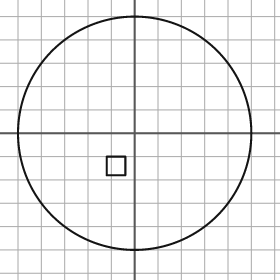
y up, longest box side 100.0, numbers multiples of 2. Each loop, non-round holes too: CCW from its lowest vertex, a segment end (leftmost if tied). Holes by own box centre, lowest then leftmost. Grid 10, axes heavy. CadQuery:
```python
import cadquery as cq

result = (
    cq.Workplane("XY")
    .moveTo(0.0, 0.0)
    .circle(50.0)
    .moveTo(-12.0, -18.0)
    .lineTo(-4.0, -18.0)
    .lineTo(-4.0, -10.0)
    .lineTo(-12.0, -10.0)
    .close()
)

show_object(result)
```